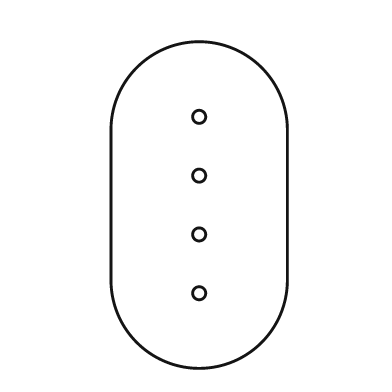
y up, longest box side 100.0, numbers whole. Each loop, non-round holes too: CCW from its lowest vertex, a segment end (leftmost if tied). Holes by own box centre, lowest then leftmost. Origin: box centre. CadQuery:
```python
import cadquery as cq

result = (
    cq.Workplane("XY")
    .moveTo(-27.0, -23.0)
    .threePointArc((0.0, -50.0), (27.0, -23.0))
    .lineTo(27.0, 23.0)
    .threePointArc((0.0, 50.0), (-27.0, 23.0))
    .close()
    .moveTo(0.0, -27.0)
    .circle(2.0)
    .moveTo(0.0, -9.0)
    .circle(2.0)
    .moveTo(0.0, 9.0)
    .circle(2.0)
    .moveTo(0.0, 27.0)
    .circle(2.0)
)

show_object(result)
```